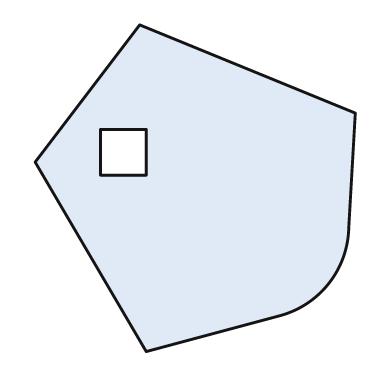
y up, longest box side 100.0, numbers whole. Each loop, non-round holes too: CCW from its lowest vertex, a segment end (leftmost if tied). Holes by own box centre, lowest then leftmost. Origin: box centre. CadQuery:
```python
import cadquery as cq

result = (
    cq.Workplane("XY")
    .moveTo(-15.0, -50.0)
    .lineTo(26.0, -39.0)
    .threePointArc((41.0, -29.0), (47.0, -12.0))
    .lineTo(49.0, 23.0)
    .lineTo(-17.0, 50.0)
    .lineTo(-49.0, 8.0)
    .close()
    .moveTo(-29.0, 4.0)
    .lineTo(-15.0, 4.0)
    .lineTo(-15.0, 18.0)
    .lineTo(-29.0, 18.0)
    .close()
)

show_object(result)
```